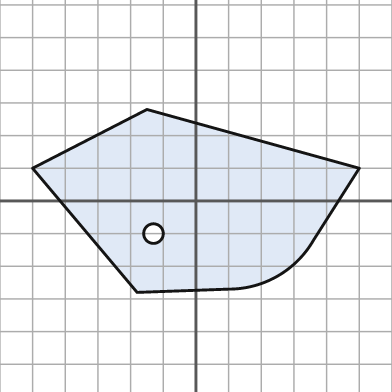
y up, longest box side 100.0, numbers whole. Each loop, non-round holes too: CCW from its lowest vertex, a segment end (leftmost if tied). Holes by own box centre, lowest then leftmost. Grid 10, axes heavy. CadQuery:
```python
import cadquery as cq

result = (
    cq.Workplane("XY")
    .moveTo(-18.0, -28.0)
    .lineTo(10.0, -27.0)
    .threePointArc((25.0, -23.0), (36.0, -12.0))
    .lineTo(50.0, 10.0)
    .lineTo(-15.0, 28.0)
    .lineTo(-50.0, 10.0)
    .close()
    .moveTo(-13.0, -10.0)
    .circle(3.0)
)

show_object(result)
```